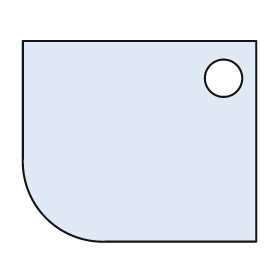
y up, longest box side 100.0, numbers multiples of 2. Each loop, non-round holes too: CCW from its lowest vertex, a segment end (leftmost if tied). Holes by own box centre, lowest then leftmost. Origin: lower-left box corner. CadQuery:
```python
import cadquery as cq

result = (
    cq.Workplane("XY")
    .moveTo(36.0, 0.0)
    .lineTo(100.0, 0.0)
    .lineTo(100.0, 86.0)
    .lineTo(0.0, 86.0)
    .lineTo(0.0, 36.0)
    .threePointArc((10.0, 10.0), (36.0, 0.0))
    .close()
    .moveTo(86.0, 70.0)
    .circle(8.0)
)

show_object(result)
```